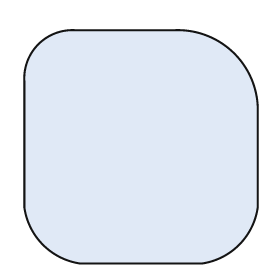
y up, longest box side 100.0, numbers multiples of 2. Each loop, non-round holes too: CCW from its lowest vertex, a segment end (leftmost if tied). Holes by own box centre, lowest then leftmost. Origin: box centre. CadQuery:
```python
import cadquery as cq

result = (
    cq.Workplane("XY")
    .moveTo(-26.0, -50.0)
    .lineTo(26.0, -50.0)
    .threePointArc((42.0, -42.0), (50.0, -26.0))
    .lineTo(50.0, 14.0)
    .threePointArc((40.0, 40.0), (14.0, 50.0))
    .lineTo(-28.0, 50.0)
    .threePointArc((-44.0, 44.0), (-50.0, 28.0))
    .lineTo(-50.0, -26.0)
    .threePointArc((-42.0, -42.0), (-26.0, -50.0))
    .close()
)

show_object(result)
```